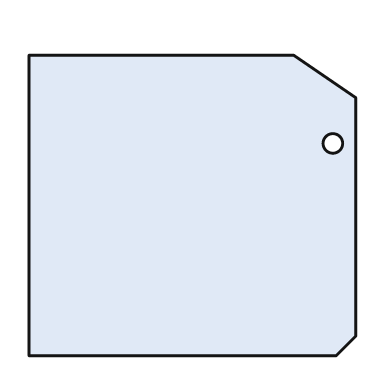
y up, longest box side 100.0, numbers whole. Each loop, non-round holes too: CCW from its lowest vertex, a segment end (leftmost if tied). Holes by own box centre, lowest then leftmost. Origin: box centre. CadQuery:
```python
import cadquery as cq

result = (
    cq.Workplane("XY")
    .moveTo(-50.0, -46.0)
    .lineTo(44.0, -46.0)
    .lineTo(50.0, -40.0)
    .lineTo(50.0, 33.0)
    .lineTo(31.0, 46.0)
    .lineTo(-50.0, 46.0)
    .close()
    .moveTo(43.0, 19.0)
    .circle(3.0)
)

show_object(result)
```